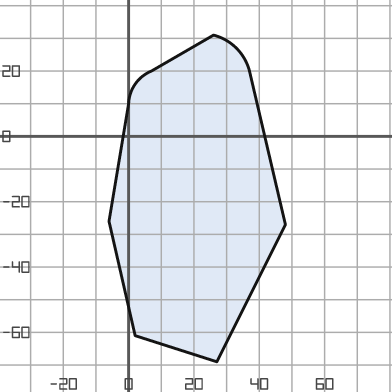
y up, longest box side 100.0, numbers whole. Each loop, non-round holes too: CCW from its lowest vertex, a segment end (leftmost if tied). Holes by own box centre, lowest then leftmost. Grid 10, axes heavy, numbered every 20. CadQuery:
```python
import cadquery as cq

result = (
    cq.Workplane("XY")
    .moveTo(27.0, -69.0)
    .lineTo(48.0, -27.0)
    .lineTo(37.0, 20.0)
    .threePointArc((33.0, 27.0), (26.0, 31.0))
    .lineTo(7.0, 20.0)
    .threePointArc((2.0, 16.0), (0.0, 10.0))
    .lineTo(-6.0, -26.0)
    .lineTo(2.0, -61.0)
    .close()
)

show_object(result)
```